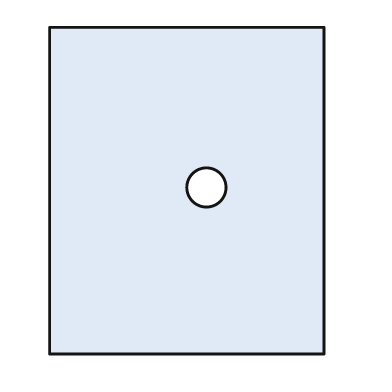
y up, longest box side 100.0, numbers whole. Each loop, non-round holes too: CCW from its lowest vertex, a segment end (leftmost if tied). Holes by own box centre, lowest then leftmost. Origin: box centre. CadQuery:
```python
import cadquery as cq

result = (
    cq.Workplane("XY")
    .moveTo(-42.0, -50.0)
    .lineTo(42.0, -50.0)
    .lineTo(42.0, 50.0)
    .lineTo(-42.0, 50.0)
    .close()
    .moveTo(6.0, 1.0)
    .circle(6.0)
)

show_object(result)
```